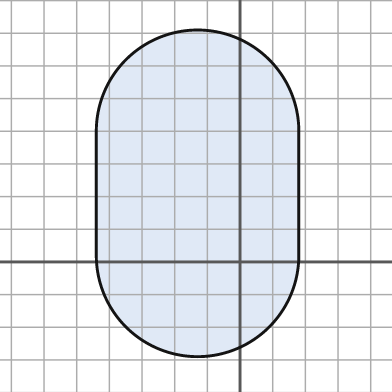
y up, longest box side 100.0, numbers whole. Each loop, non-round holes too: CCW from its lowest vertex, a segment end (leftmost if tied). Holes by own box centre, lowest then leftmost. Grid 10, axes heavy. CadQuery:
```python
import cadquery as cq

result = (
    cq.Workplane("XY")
    .moveTo(-44.0, 2.0)
    .threePointArc((-13.0, -29.0), (18.0, 2.0))
    .lineTo(18.0, 40.0)
    .threePointArc((-13.0, 71.0), (-44.0, 40.0))
    .close()
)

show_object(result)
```